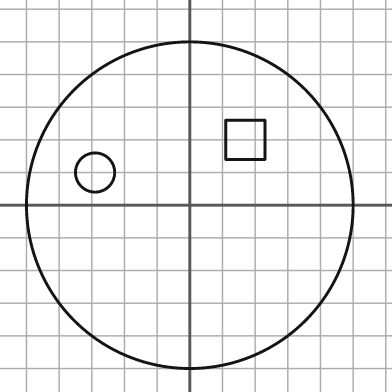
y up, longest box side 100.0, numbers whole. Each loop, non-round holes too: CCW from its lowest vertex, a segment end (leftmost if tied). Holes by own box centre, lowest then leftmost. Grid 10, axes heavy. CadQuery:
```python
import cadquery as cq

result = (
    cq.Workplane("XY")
    .moveTo(0.0, 0.0)
    .circle(50.0)
    .moveTo(-29.0, 10.0)
    .circle(6.0)
    .moveTo(11.0, 14.0)
    .lineTo(23.0, 14.0)
    .lineTo(23.0, 26.0)
    .lineTo(11.0, 26.0)
    .close()
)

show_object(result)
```